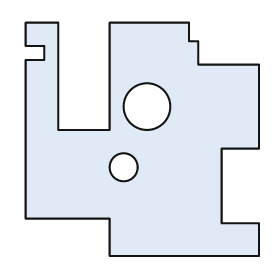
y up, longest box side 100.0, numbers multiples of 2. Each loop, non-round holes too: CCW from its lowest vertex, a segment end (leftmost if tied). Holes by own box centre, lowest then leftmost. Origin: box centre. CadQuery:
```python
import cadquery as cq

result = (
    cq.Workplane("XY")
    .moveTo(-14.0, -50.0)
    .lineTo(50.0, -50.0)
    .lineTo(50.0, -36.0)
    .lineTo(34.0, -36.0)
    .lineTo(34.0, -4.0)
    .lineTo(50.0, -4.0)
    .lineTo(50.0, 32.0)
    .lineTo(24.0, 32.0)
    .lineTo(24.0, 42.0)
    .lineTo(20.0, 42.0)
    .lineTo(20.0, 50.0)
    .lineTo(-14.0, 50.0)
    .lineTo(-14.0, 4.0)
    .lineTo(-36.0, 4.0)
    .lineTo(-36.0, 50.0)
    .lineTo(-50.0, 50.0)
    .lineTo(-50.0, 40.0)
    .lineTo(-42.0, 40.0)
    .lineTo(-42.0, 34.0)
    .lineTo(-50.0, 34.0)
    .lineTo(-50.0, -34.0)
    .lineTo(-14.0, -34.0)
    .close()
    .moveTo(-8.0, -12.0)
    .circle(6.0)
    .moveTo(2.0, 14.0)
    .circle(10.0)
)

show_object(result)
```